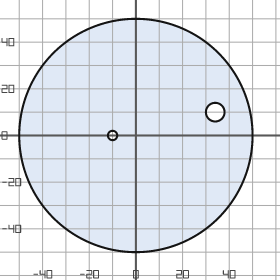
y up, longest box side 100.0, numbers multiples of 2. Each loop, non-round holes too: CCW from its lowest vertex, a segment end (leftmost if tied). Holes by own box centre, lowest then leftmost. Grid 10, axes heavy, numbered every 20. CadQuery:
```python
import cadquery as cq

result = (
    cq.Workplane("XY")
    .moveTo(0.0, 0.0)
    .circle(50.0)
    .moveTo(-10.0, 0.0)
    .circle(2.0)
    .moveTo(34.0, 10.0)
    .circle(4.0)
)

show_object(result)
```